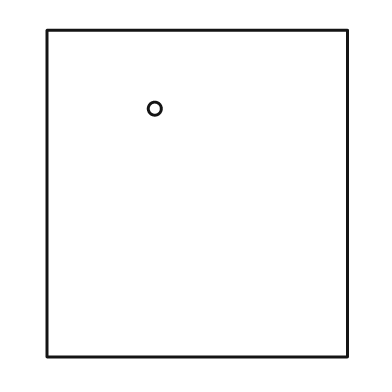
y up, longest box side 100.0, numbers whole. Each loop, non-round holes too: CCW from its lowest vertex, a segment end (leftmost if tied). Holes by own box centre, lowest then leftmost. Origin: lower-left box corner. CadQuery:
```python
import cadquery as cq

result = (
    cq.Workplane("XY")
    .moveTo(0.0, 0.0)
    .lineTo(92.0, 0.0)
    .lineTo(92.0, 100.0)
    .lineTo(0.0, 100.0)
    .close()
    .moveTo(33.0, 76.0)
    .circle(2.0)
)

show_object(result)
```